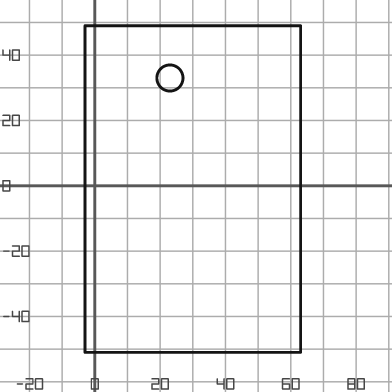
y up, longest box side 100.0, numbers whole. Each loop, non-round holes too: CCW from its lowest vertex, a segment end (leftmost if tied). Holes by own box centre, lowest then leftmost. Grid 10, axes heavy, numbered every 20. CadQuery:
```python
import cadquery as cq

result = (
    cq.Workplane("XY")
    .moveTo(-3.0, -51.0)
    .lineTo(63.0, -51.0)
    .lineTo(63.0, 49.0)
    .lineTo(-3.0, 49.0)
    .close()
    .moveTo(23.0, 33.0)
    .circle(4.0)
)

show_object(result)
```